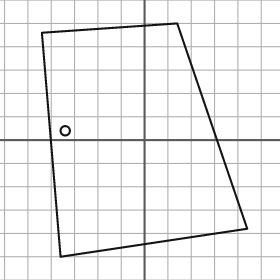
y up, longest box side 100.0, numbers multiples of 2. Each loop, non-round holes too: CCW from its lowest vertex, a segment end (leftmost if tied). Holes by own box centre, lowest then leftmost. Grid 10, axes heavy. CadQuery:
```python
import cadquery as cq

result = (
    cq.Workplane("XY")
    .moveTo(-36.0, -50.0)
    .lineTo(44.0, -38.0)
    .lineTo(14.0, 50.0)
    .lineTo(-44.0, 46.0)
    .close()
    .moveTo(-34.0, 4.0)
    .circle(2.0)
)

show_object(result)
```